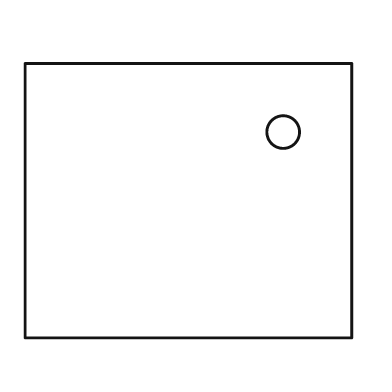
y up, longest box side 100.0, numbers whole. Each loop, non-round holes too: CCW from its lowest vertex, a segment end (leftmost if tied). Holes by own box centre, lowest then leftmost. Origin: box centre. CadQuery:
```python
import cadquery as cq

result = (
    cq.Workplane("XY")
    .moveTo(-50.0, -42.0)
    .lineTo(50.0, -42.0)
    .lineTo(50.0, 42.0)
    .lineTo(-50.0, 42.0)
    .close()
    .moveTo(29.0, 21.0)
    .circle(5.0)
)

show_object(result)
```